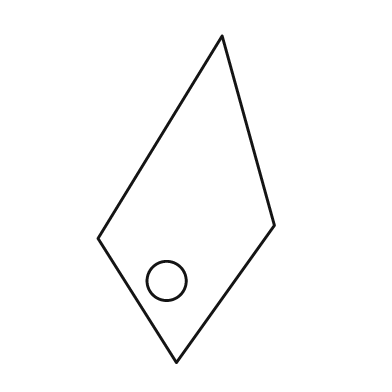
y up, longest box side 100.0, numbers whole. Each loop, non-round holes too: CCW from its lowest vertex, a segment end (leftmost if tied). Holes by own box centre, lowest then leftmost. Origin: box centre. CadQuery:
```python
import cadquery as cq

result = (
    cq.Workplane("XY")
    .moveTo(-3.0, -50.0)
    .lineTo(27.0, -8.0)
    .lineTo(11.0, 50.0)
    .lineTo(-27.0, -12.0)
    .close()
    .moveTo(-6.0, -25.0)
    .circle(6.0)
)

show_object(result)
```